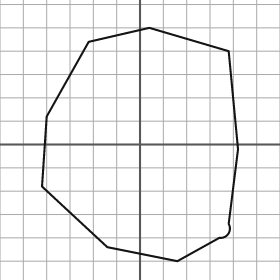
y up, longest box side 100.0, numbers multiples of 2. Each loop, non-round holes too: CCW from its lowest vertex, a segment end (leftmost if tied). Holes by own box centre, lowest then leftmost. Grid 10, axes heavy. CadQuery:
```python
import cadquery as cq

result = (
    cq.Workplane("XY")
    .moveTo(16.0, -50.0)
    .lineTo(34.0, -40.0)
    .threePointArc((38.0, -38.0), (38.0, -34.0))
    .lineTo(42.0, -2.0)
    .lineTo(38.0, 40.0)
    .lineTo(4.0, 50.0)
    .lineTo(-22.0, 44.0)
    .lineTo(-40.0, 12.0)
    .lineTo(-42.0, -18.0)
    .lineTo(-14.0, -44.0)
    .close()
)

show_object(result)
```